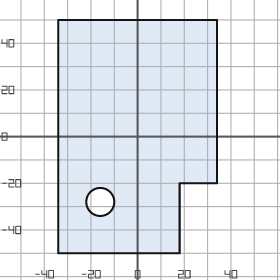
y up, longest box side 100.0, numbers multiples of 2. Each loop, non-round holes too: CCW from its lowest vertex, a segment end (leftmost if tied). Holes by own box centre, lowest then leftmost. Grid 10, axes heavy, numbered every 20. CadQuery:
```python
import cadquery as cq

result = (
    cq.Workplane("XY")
    .moveTo(-34.0, -50.0)
    .lineTo(18.0, -50.0)
    .lineTo(18.0, -20.0)
    .lineTo(34.0, -20.0)
    .lineTo(34.0, 50.0)
    .lineTo(-34.0, 50.0)
    .close()
    .moveTo(-16.0, -28.0)
    .circle(6.0)
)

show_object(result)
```